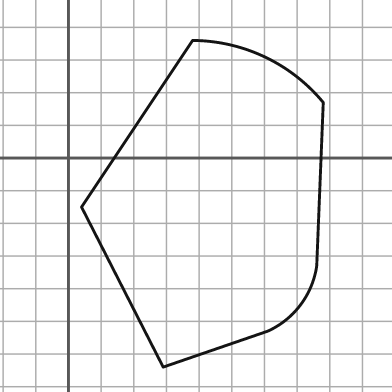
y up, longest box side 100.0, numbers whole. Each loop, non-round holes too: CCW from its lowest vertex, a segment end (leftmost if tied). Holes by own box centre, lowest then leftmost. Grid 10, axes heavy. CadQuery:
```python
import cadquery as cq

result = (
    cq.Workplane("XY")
    .moveTo(29.0, -64.0)
    .lineTo(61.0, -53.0)
    .threePointArc((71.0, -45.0), (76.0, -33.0))
    .lineTo(78.0, 17.0)
    .threePointArc((60.0, 31.0), (38.0, 36.0))
    .lineTo(4.0, -15.0)
    .close()
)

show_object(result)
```